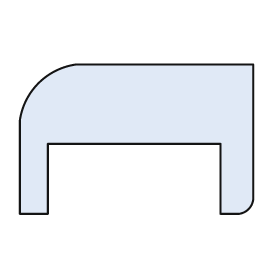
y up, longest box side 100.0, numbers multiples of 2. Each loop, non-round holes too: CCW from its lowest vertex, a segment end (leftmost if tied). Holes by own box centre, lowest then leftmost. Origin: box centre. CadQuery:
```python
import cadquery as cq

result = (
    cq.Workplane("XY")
    .moveTo(-50.0, -32.0)
    .lineTo(-38.0, -32.0)
    .lineTo(-38.0, -2.0)
    .lineTo(36.0, -2.0)
    .lineTo(36.0, -32.0)
    .lineTo(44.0, -32.0)
    .threePointArc((48.0, -30.0), (50.0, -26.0))
    .lineTo(50.0, 32.0)
    .lineTo(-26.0, 32.0)
    .threePointArc((-42.0, 24.0), (-50.0, 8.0))
    .close()
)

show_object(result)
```